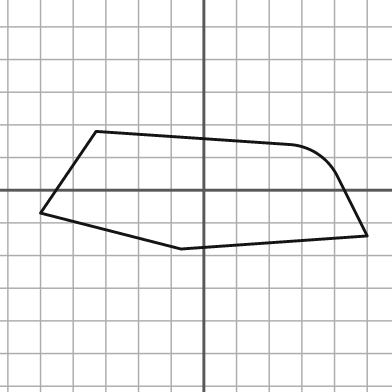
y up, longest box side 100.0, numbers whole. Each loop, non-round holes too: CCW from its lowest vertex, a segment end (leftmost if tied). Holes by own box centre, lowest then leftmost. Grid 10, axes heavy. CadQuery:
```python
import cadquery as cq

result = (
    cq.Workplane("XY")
    .moveTo(-7.0, -18.0)
    .lineTo(50.0, -14.0)
    .lineTo(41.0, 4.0)
    .threePointArc((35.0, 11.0), (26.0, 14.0))
    .lineTo(-33.0, 18.0)
    .lineTo(-50.0, -7.0)
    .close()
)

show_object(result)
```